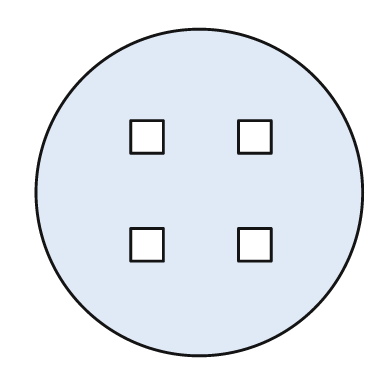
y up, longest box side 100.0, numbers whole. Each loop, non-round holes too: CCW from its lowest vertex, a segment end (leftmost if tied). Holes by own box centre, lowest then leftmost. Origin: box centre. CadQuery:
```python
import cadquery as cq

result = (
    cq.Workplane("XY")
    .moveTo(0.0, 0.0)
    .circle(50.0)
    .moveTo(-21.0, -21.0)
    .lineTo(-11.0, -21.0)
    .lineTo(-11.0, -11.0)
    .lineTo(-21.0, -11.0)
    .close()
    .moveTo(12.0, -21.0)
    .lineTo(22.0, -21.0)
    .lineTo(22.0, -11.0)
    .lineTo(12.0, -11.0)
    .close()
    .moveTo(-21.0, 12.0)
    .lineTo(-11.0, 12.0)
    .lineTo(-11.0, 22.0)
    .lineTo(-21.0, 22.0)
    .close()
    .moveTo(12.0, 12.0)
    .lineTo(22.0, 12.0)
    .lineTo(22.0, 22.0)
    .lineTo(12.0, 22.0)
    .close()
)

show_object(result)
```